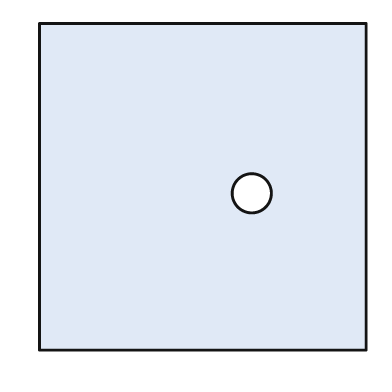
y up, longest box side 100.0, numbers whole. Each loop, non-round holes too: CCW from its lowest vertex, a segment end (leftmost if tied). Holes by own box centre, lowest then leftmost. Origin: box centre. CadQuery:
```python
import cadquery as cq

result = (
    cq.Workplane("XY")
    .moveTo(-50.0, -50.0)
    .lineTo(50.0, -50.0)
    .lineTo(50.0, 50.0)
    .lineTo(-50.0, 50.0)
    .close()
    .moveTo(15.0, -2.0)
    .circle(6.0)
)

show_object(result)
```